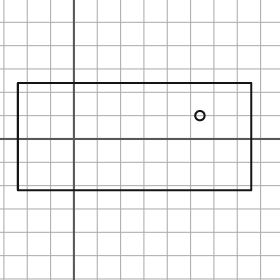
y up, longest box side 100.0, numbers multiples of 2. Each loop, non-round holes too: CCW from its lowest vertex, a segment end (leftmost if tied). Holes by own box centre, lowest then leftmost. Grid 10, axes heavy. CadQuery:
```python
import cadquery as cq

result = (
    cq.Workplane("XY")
    .moveTo(-24.0, -22.0)
    .lineTo(76.0, -22.0)
    .lineTo(76.0, 24.0)
    .lineTo(-24.0, 24.0)
    .close()
    .moveTo(54.0, 10.0)
    .circle(2.0)
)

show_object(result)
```